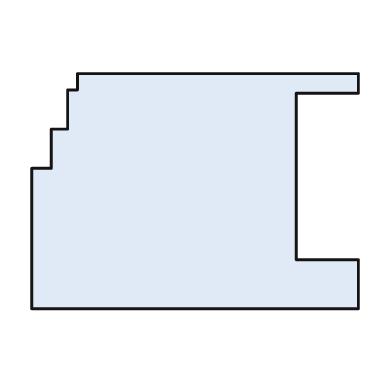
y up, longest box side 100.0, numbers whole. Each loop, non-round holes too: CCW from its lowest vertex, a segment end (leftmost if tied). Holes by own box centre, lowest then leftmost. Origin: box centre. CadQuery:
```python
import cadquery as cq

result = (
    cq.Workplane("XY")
    .moveTo(-50.0, -36.0)
    .lineTo(50.0, -36.0)
    .lineTo(50.0, -21.0)
    .lineTo(31.0, -21.0)
    .lineTo(31.0, 30.0)
    .lineTo(50.0, 30.0)
    .lineTo(50.0, 36.0)
    .lineTo(-36.0, 36.0)
    .lineTo(-36.0, 31.0)
    .lineTo(-39.0, 31.0)
    .lineTo(-39.0, 19.0)
    .lineTo(-44.0, 19.0)
    .lineTo(-44.0, 7.0)
    .lineTo(-50.0, 7.0)
    .close()
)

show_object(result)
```